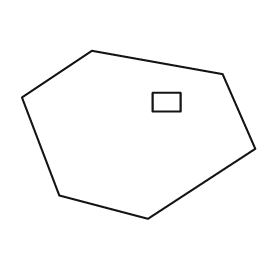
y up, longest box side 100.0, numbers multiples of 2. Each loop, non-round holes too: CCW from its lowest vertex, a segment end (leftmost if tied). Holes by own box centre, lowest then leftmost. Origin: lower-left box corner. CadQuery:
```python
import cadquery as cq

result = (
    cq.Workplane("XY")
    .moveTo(54.0, 0.0)
    .lineTo(100.0, 30.0)
    .lineTo(86.0, 62.0)
    .lineTo(30.0, 72.0)
    .lineTo(0.0, 52.0)
    .lineTo(16.0, 10.0)
    .close()
    .moveTo(56.0, 46.0)
    .lineTo(68.0, 46.0)
    .lineTo(68.0, 54.0)
    .lineTo(56.0, 54.0)
    .close()
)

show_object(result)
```